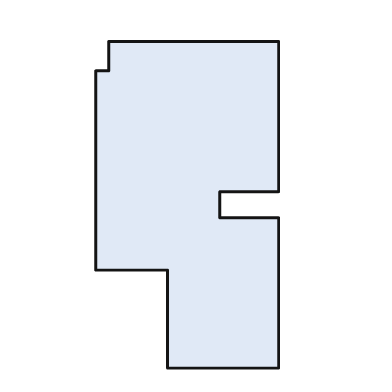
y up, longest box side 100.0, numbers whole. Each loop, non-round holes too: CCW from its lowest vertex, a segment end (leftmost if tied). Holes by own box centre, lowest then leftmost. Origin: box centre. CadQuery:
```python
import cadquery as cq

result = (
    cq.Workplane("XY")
    .moveTo(-6.0, -50.0)
    .lineTo(28.0, -50.0)
    .lineTo(28.0, -4.0)
    .lineTo(10.0, -4.0)
    .lineTo(10.0, 4.0)
    .lineTo(28.0, 4.0)
    .lineTo(28.0, 50.0)
    .lineTo(-24.0, 50.0)
    .lineTo(-24.0, 41.0)
    .lineTo(-28.0, 41.0)
    .lineTo(-28.0, -20.0)
    .lineTo(-6.0, -20.0)
    .close()
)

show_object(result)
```